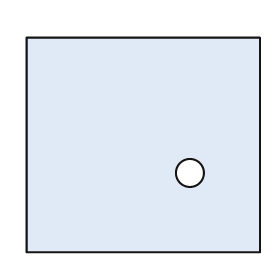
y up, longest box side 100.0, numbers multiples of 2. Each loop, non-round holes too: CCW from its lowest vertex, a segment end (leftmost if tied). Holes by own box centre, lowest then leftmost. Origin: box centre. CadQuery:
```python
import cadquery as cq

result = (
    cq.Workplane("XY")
    .moveTo(-50.0, -46.0)
    .lineTo(50.0, -46.0)
    .lineTo(50.0, 46.0)
    .lineTo(-50.0, 46.0)
    .close()
    .moveTo(20.0, -12.0)
    .circle(6.0)
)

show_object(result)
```